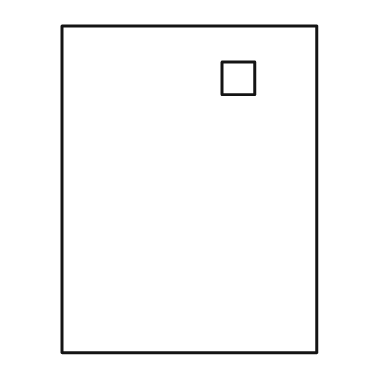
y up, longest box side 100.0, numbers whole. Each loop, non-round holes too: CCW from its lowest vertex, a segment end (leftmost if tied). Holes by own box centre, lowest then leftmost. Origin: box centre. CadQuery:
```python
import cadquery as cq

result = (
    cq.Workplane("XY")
    .moveTo(-39.0, -50.0)
    .lineTo(39.0, -50.0)
    .lineTo(39.0, 50.0)
    .lineTo(-39.0, 50.0)
    .close()
    .moveTo(10.0, 29.0)
    .lineTo(20.0, 29.0)
    .lineTo(20.0, 39.0)
    .lineTo(10.0, 39.0)
    .close()
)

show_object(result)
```